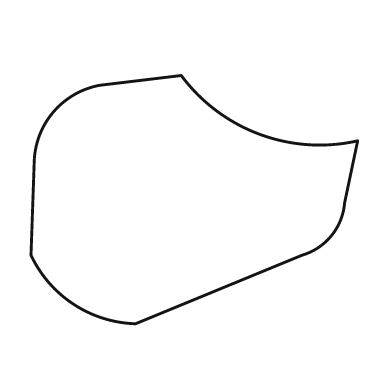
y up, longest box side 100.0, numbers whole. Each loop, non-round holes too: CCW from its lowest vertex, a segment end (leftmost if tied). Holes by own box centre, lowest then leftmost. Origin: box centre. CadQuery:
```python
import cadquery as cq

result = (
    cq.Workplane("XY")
    .moveTo(-18.0, -38.0)
    .lineTo(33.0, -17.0)
    .threePointArc((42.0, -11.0), (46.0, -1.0))
    .lineTo(50.0, 18.0)
    .threePointArc((20.0, 20.0), (-4.0, 38.0))
    .lineTo(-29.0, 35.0)
    .threePointArc((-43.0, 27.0), (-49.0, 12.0))
    .lineTo(-50.0, -17.0)
    .threePointArc((-37.0, -32.0), (-18.0, -38.0))
    .close()
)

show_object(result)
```